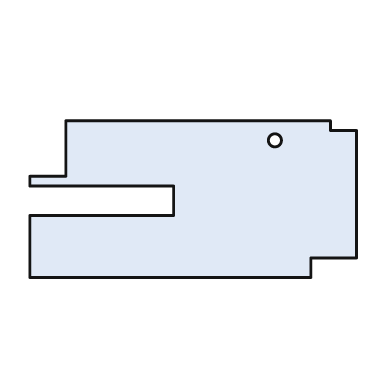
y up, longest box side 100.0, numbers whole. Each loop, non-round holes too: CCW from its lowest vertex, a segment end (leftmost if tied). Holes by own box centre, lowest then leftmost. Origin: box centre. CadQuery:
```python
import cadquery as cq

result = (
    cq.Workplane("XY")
    .moveTo(-50.0, -24.0)
    .lineTo(36.0, -24.0)
    .lineTo(36.0, -18.0)
    .lineTo(50.0, -18.0)
    .lineTo(50.0, 21.0)
    .lineTo(42.0, 21.0)
    .lineTo(42.0, 24.0)
    .lineTo(-39.0, 24.0)
    .lineTo(-39.0, 7.0)
    .lineTo(-50.0, 7.0)
    .lineTo(-50.0, 4.0)
    .lineTo(-6.0, 4.0)
    .lineTo(-6.0, -5.0)
    .lineTo(-50.0, -5.0)
    .close()
    .moveTo(25.0, 18.0)
    .circle(2.0)
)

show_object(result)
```